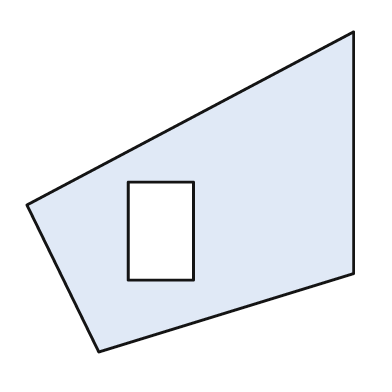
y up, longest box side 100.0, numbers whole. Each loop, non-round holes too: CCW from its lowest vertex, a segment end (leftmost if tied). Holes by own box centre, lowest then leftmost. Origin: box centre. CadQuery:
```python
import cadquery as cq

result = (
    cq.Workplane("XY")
    .moveTo(-28.0, -49.0)
    .lineTo(50.0, -25.0)
    .lineTo(50.0, 49.0)
    .lineTo(-50.0, -4.0)
    .close()
    .moveTo(-19.0, -27.0)
    .lineTo(1.0, -27.0)
    .lineTo(1.0, 3.0)
    .lineTo(-19.0, 3.0)
    .close()
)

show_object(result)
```